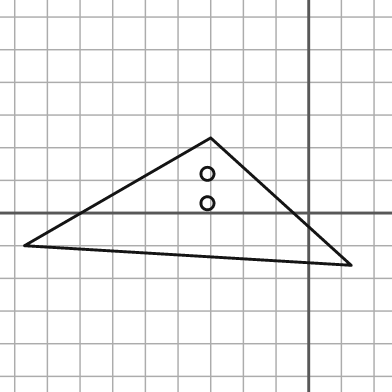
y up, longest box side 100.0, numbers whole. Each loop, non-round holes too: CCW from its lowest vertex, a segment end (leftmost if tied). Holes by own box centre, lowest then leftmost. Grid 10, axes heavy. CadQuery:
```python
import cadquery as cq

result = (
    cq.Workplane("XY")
    .moveTo(13.0, -16.0)
    .lineTo(-30.0, 23.0)
    .lineTo(-87.0, -10.0)
    .close()
    .moveTo(-31.0, 3.0)
    .circle(2.0)
    .moveTo(-31.0, 12.0)
    .circle(2.0)
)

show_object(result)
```